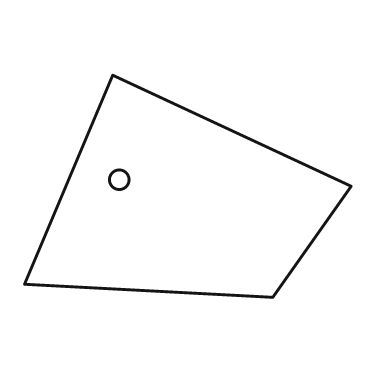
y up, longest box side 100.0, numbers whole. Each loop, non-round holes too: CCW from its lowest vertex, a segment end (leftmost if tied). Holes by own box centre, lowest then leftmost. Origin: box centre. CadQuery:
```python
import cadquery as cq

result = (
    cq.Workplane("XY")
    .moveTo(26.0, -34.0)
    .lineTo(50.0, 0.0)
    .lineTo(-23.0, 34.0)
    .lineTo(-50.0, -30.0)
    .close()
    .moveTo(-21.0, 2.0)
    .circle(3.0)
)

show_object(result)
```